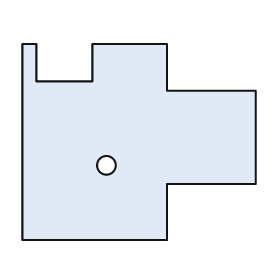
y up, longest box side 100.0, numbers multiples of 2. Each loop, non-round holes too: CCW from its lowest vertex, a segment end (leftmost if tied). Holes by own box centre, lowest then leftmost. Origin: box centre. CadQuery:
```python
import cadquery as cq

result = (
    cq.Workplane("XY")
    .moveTo(-50.0, -42.0)
    .lineTo(12.0, -42.0)
    .lineTo(12.0, -18.0)
    .lineTo(50.0, -18.0)
    .lineTo(50.0, 22.0)
    .lineTo(12.0, 22.0)
    .lineTo(12.0, 42.0)
    .lineTo(-20.0, 42.0)
    .lineTo(-20.0, 26.0)
    .lineTo(-44.0, 26.0)
    .lineTo(-44.0, 42.0)
    .lineTo(-50.0, 42.0)
    .close()
    .moveTo(-14.0, -10.0)
    .circle(4.0)
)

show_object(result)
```